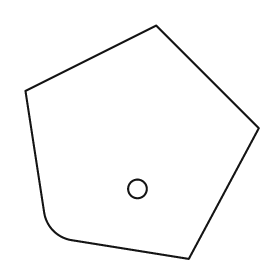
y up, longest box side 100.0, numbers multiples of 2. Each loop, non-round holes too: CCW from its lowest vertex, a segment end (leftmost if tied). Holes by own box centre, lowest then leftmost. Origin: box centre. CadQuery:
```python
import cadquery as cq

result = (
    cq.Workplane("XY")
    .moveTo(20.0, -50.0)
    .lineTo(50.0, 6.0)
    .lineTo(6.0, 50.0)
    .lineTo(-50.0, 22.0)
    .lineTo(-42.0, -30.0)
    .threePointArc((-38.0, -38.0), (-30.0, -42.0))
    .close()
    .moveTo(-2.0, -20.0)
    .circle(4.0)
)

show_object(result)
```